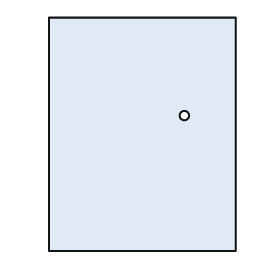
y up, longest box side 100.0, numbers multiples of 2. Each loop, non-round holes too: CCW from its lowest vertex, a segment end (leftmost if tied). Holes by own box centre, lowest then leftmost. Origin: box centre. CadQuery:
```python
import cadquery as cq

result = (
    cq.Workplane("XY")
    .moveTo(-40.0, -50.0)
    .lineTo(40.0, -50.0)
    .lineTo(40.0, 50.0)
    .lineTo(-40.0, 50.0)
    .close()
    .moveTo(18.0, 8.0)
    .circle(2.0)
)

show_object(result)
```